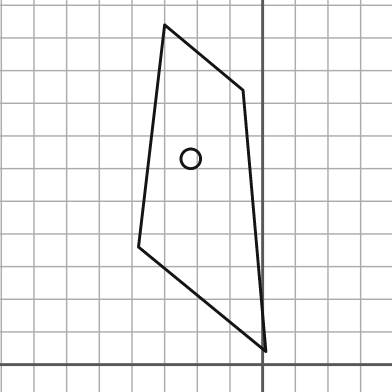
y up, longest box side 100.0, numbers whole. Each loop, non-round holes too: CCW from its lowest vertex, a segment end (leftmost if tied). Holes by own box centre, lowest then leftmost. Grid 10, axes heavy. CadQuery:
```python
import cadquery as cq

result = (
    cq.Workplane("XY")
    .moveTo(1.0, 4.0)
    .lineTo(-6.0, 84.0)
    .lineTo(-30.0, 104.0)
    .lineTo(-38.0, 36.0)
    .close()
    .moveTo(-22.0, 63.0)
    .circle(3.0)
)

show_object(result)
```